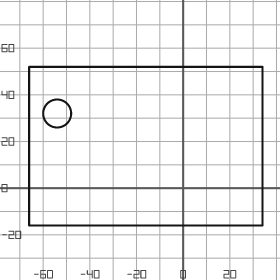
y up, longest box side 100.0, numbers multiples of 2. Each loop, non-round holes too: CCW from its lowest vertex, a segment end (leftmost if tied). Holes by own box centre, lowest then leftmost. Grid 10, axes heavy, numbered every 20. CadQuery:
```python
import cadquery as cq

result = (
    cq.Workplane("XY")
    .moveTo(-66.0, -16.0)
    .lineTo(34.0, -16.0)
    .lineTo(34.0, 52.0)
    .lineTo(-66.0, 52.0)
    .close()
    .moveTo(-54.0, 32.0)
    .circle(6.0)
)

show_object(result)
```